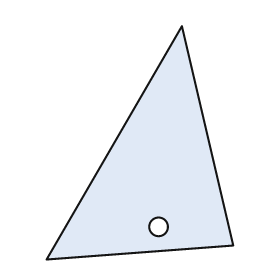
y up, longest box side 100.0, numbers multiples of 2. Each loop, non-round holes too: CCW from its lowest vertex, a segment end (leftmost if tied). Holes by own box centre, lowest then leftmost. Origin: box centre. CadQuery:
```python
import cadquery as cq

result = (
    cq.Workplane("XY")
    .moveTo(-40.0, -50.0)
    .lineTo(40.0, -44.0)
    .lineTo(18.0, 50.0)
    .close()
    .moveTo(8.0, -36.0)
    .circle(4.0)
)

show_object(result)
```